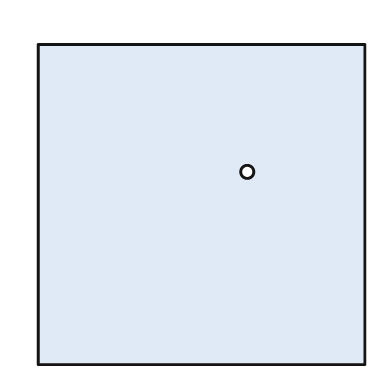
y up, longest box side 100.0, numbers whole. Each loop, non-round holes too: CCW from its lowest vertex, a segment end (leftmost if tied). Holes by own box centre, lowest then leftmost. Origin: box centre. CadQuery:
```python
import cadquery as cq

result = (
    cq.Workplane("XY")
    .moveTo(-50.0, -49.0)
    .lineTo(50.0, -49.0)
    .lineTo(50.0, 49.0)
    .lineTo(-50.0, 49.0)
    .close()
    .moveTo(14.0, 10.0)
    .circle(2.0)
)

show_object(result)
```